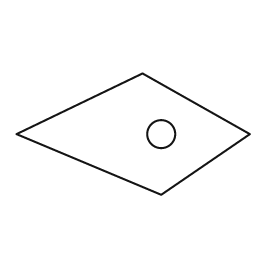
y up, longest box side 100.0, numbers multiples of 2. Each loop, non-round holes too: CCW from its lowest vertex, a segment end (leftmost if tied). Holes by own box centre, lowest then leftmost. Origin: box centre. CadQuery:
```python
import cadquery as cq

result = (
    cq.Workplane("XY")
    .moveTo(12.0, -26.0)
    .lineTo(50.0, 0.0)
    .lineTo(4.0, 26.0)
    .lineTo(-50.0, 0.0)
    .close()
    .moveTo(12.0, 0.0)
    .circle(6.0)
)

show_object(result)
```